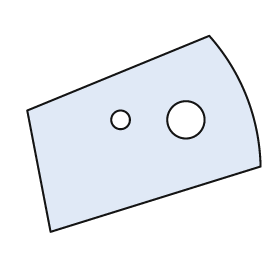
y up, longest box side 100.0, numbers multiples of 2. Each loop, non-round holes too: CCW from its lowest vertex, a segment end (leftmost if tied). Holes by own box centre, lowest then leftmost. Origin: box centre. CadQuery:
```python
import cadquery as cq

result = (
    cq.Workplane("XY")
    .moveTo(-40.0, -42.0)
    .lineTo(50.0, -14.0)
    .threePointArc((44.0, 16.0), (28.0, 42.0))
    .lineTo(-50.0, 10.0)
    .close()
    .moveTo(-10.0, 6.0)
    .circle(4.0)
    .moveTo(18.0, 6.0)
    .circle(8.0)
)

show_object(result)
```